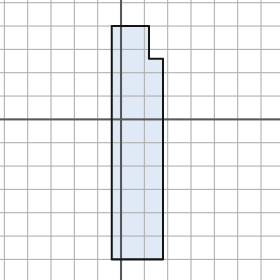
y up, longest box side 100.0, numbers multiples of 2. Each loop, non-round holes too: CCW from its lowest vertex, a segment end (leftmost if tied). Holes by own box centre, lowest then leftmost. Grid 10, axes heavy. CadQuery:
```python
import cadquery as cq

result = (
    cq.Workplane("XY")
    .moveTo(-4.0, -60.0)
    .lineTo(18.0, -60.0)
    .lineTo(18.0, 26.0)
    .lineTo(12.0, 26.0)
    .lineTo(12.0, 40.0)
    .lineTo(-4.0, 40.0)
    .close()
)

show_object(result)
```